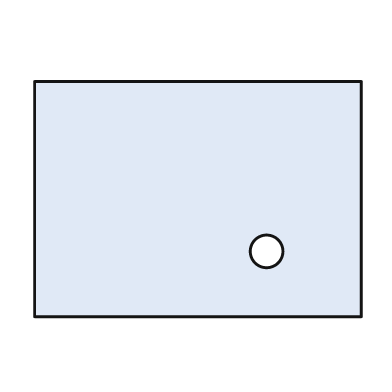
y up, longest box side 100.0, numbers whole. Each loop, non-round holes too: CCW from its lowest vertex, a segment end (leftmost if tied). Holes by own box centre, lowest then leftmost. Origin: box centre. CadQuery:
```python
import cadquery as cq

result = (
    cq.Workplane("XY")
    .moveTo(-50.0, -36.0)
    .lineTo(50.0, -36.0)
    .lineTo(50.0, 36.0)
    .lineTo(-50.0, 36.0)
    .close()
    .moveTo(21.0, -16.0)
    .circle(5.0)
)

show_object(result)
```